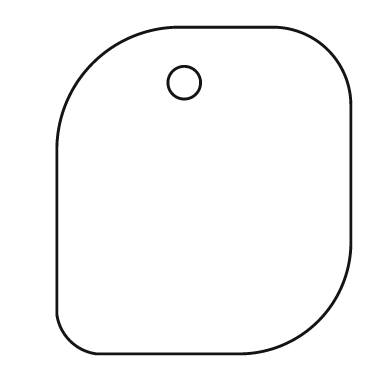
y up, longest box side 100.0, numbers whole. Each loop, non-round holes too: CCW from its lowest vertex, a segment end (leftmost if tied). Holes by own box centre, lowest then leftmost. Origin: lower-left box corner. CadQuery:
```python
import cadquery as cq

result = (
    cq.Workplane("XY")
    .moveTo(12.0, 0.0)
    .lineTo(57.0, 0.0)
    .threePointArc((80.0, 10.0), (90.0, 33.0))
    .lineTo(90.0, 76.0)
    .threePointArc((83.0, 93.0), (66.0, 100.0))
    .lineTo(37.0, 100.0)
    .threePointArc((11.0, 89.0), (0.0, 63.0))
    .lineTo(0.0, 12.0)
    .threePointArc((4.0, 4.0), (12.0, 0.0))
    .close()
    .moveTo(39.0, 83.0)
    .circle(5.0)
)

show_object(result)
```